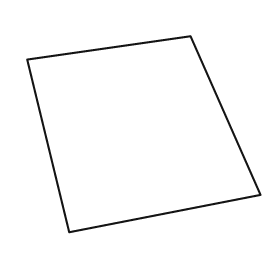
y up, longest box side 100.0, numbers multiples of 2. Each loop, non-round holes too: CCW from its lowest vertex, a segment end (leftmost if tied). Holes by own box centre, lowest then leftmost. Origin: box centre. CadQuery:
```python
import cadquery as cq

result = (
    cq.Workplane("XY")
    .moveTo(-32.0, -42.0)
    .lineTo(50.0, -26.0)
    .lineTo(20.0, 42.0)
    .lineTo(-50.0, 32.0)
    .close()
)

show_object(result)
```